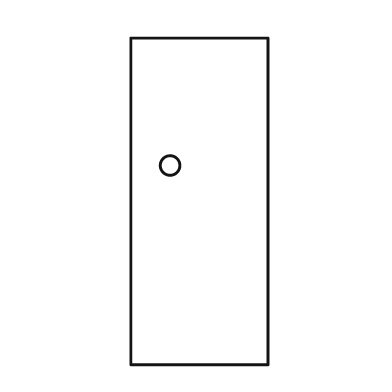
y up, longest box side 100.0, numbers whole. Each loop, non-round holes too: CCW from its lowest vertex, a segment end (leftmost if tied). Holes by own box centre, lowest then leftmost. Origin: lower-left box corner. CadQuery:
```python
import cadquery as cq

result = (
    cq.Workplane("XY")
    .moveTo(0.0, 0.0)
    .lineTo(42.0, 0.0)
    .lineTo(42.0, 100.0)
    .lineTo(0.0, 100.0)
    .close()
    .moveTo(12.0, 61.0)
    .circle(3.0)
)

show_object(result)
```